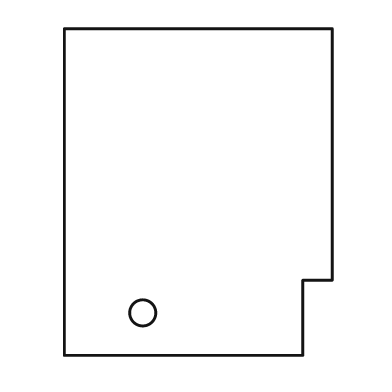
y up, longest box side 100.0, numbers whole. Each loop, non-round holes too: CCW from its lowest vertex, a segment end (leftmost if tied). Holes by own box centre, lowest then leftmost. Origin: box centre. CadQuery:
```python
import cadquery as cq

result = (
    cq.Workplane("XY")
    .moveTo(-41.0, -50.0)
    .lineTo(32.0, -50.0)
    .lineTo(32.0, -27.0)
    .lineTo(41.0, -27.0)
    .lineTo(41.0, 50.0)
    .lineTo(-41.0, 50.0)
    .close()
    .moveTo(-17.0, -37.0)
    .circle(4.0)
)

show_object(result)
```